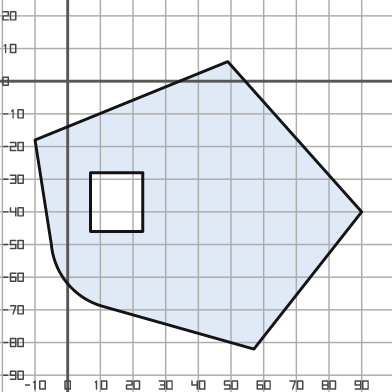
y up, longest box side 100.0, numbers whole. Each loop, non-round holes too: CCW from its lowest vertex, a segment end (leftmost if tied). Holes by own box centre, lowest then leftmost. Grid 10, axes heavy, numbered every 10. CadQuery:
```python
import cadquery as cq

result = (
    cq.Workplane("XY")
    .moveTo(57.0, -82.0)
    .lineTo(90.0, -40.0)
    .lineTo(49.0, 6.0)
    .lineTo(-10.0, -18.0)
    .lineTo(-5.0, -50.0)
    .threePointArc((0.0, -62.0), (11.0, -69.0))
    .close()
    .moveTo(7.0, -46.0)
    .lineTo(23.0, -46.0)
    .lineTo(23.0, -28.0)
    .lineTo(7.0, -28.0)
    .close()
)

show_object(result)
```